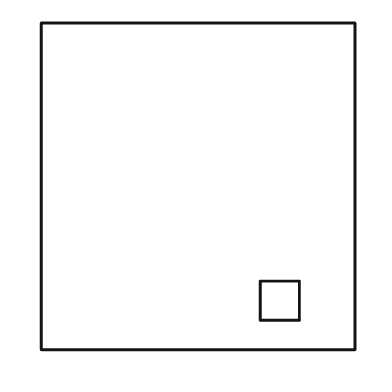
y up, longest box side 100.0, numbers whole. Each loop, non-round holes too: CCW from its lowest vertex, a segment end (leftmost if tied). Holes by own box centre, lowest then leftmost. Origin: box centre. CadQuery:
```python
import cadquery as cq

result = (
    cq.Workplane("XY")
    .moveTo(-48.0, -50.0)
    .lineTo(48.0, -50.0)
    .lineTo(48.0, 50.0)
    .lineTo(-48.0, 50.0)
    .close()
    .moveTo(19.0, -41.0)
    .lineTo(31.0, -41.0)
    .lineTo(31.0, -29.0)
    .lineTo(19.0, -29.0)
    .close()
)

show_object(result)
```